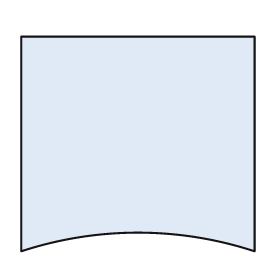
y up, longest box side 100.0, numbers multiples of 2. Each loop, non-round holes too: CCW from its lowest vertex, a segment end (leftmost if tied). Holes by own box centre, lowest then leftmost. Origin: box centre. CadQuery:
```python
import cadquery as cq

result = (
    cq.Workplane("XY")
    .moveTo(-50.0, -46.0)
    .threePointArc((0.0, -38.0), (50.0, -46.0))
    .lineTo(50.0, 46.0)
    .lineTo(-50.0, 46.0)
    .close()
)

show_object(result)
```